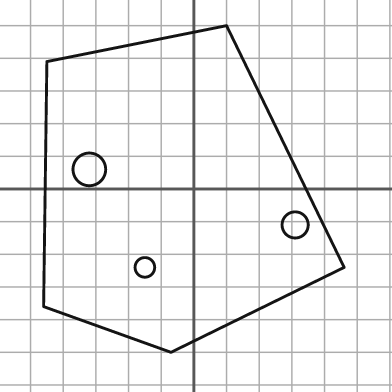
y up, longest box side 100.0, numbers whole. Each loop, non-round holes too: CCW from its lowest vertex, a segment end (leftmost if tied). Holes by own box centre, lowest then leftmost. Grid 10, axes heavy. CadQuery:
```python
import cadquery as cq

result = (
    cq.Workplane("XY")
    .moveTo(-7.0, -50.0)
    .lineTo(46.0, -24.0)
    .lineTo(10.0, 50.0)
    .lineTo(-45.0, 39.0)
    .lineTo(-46.0, -36.0)
    .close()
    .moveTo(-15.0, -24.0)
    .circle(3.0)
    .moveTo(31.0, -11.0)
    .circle(4.0)
    .moveTo(-32.0, 6.0)
    .circle(5.0)
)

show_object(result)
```